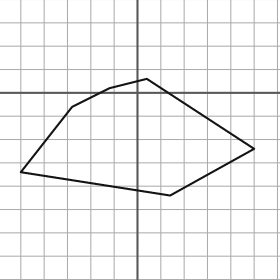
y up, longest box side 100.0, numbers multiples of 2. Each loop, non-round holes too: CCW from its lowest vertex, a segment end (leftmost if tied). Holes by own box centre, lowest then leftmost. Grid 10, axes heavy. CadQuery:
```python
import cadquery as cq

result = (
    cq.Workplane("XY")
    .moveTo(14.0, -44.0)
    .lineTo(50.0, -24.0)
    .lineTo(4.0, 6.0)
    .lineTo(-12.0, 2.0)
    .lineTo(-28.0, -6.0)
    .lineTo(-50.0, -34.0)
    .close()
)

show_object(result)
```